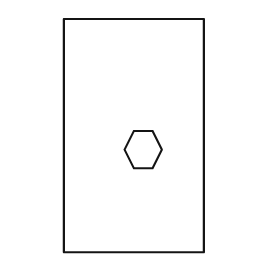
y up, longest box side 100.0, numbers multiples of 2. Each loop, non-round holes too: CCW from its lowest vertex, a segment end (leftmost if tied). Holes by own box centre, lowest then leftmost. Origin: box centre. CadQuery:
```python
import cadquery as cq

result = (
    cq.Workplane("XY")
    .moveTo(-30.0, -50.0)
    .lineTo(30.0, -50.0)
    .lineTo(30.0, 50.0)
    .lineTo(-30.0, 50.0)
    .close()
    .moveTo(0.0, -14.0)
    .lineTo(8.0, -14.0)
    .lineTo(12.0, -6.0)
    .lineTo(8.0, 2.0)
    .lineTo(0.0, 2.0)
    .lineTo(-4.0, -6.0)
    .close()
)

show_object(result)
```